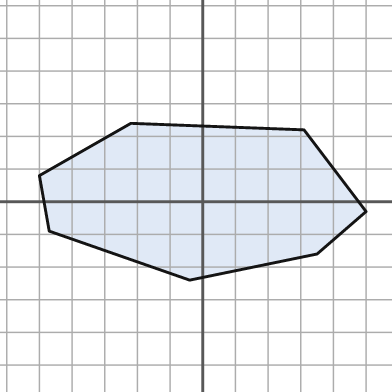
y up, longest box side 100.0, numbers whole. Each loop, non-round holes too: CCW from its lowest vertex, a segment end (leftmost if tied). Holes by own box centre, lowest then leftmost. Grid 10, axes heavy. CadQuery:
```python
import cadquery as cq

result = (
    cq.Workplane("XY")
    .moveTo(-4.0, -24.0)
    .lineTo(35.0, -16.0)
    .lineTo(50.0, -3.0)
    .lineTo(31.0, 22.0)
    .lineTo(-22.0, 24.0)
    .lineTo(-50.0, 8.0)
    .lineTo(-47.0, -9.0)
    .close()
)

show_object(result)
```